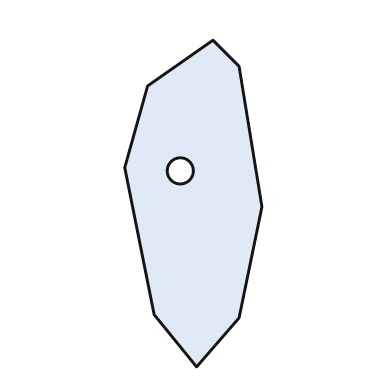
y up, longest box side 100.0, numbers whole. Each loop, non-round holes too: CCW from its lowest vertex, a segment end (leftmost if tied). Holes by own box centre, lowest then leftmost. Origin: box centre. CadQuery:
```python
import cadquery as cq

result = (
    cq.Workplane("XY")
    .moveTo(1.0, -50.0)
    .lineTo(14.0, -35.0)
    .lineTo(21.0, -1.0)
    .lineTo(14.0, 42.0)
    .lineTo(6.0, 50.0)
    .lineTo(-14.0, 36.0)
    .lineTo(-21.0, 11.0)
    .lineTo(-12.0, -34.0)
    .close()
    .moveTo(-4.0, 10.0)
    .circle(4.0)
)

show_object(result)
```